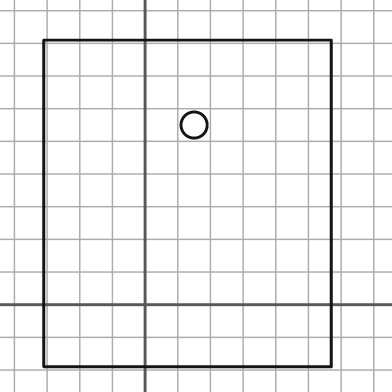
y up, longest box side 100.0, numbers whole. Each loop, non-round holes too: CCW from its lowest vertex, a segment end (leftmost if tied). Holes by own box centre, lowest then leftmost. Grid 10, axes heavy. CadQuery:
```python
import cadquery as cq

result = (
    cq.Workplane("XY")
    .moveTo(-31.0, -19.0)
    .lineTo(57.0, -19.0)
    .lineTo(57.0, 81.0)
    .lineTo(-31.0, 81.0)
    .close()
    .moveTo(15.0, 55.0)
    .circle(4.0)
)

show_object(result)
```